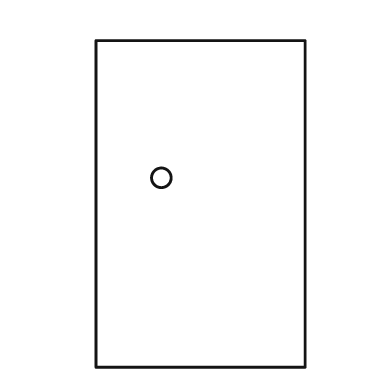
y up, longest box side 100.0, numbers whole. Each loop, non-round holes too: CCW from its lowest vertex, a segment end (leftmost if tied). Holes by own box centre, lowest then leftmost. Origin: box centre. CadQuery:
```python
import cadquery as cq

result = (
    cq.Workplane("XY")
    .moveTo(-32.0, -50.0)
    .lineTo(32.0, -50.0)
    .lineTo(32.0, 50.0)
    .lineTo(-32.0, 50.0)
    .close()
    .moveTo(-12.0, 8.0)
    .circle(3.0)
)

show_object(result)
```